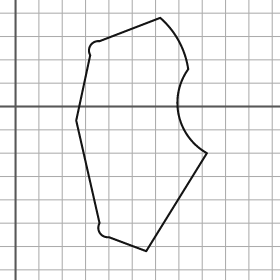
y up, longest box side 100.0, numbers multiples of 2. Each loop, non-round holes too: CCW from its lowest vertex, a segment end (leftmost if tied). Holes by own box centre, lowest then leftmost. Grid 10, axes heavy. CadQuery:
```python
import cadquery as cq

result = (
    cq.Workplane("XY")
    .moveTo(56.0, -62.0)
    .lineTo(82.0, -20.0)
    .threePointArc((70.0, -4.0), (74.0, 16.0))
    .threePointArc((70.0, 28.0), (62.0, 38.0))
    .lineTo(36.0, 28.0)
    .threePointArc((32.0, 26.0), (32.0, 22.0))
    .lineTo(26.0, -6.0)
    .lineTo(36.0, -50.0)
    .threePointArc((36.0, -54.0), (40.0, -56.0))
    .close()
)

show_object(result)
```